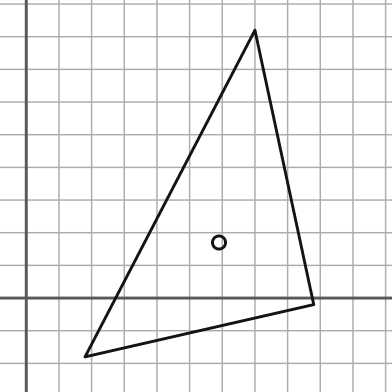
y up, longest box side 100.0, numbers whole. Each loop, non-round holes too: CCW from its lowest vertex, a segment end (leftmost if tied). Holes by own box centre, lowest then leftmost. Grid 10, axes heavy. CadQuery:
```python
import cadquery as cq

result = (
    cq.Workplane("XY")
    .moveTo(18.0, -18.0)
    .lineTo(88.0, -2.0)
    .lineTo(70.0, 82.0)
    .close()
    .moveTo(59.0, 17.0)
    .circle(2.0)
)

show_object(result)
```